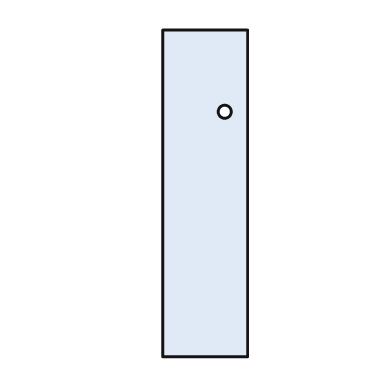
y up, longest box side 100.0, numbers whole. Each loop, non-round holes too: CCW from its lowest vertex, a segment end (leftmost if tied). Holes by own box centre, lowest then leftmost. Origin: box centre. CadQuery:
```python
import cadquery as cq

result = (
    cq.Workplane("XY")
    .moveTo(-13.0, -50.0)
    .lineTo(13.0, -50.0)
    .lineTo(13.0, 50.0)
    .lineTo(-13.0, 50.0)
    .close()
    .moveTo(6.0, 25.0)
    .circle(2.0)
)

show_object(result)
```